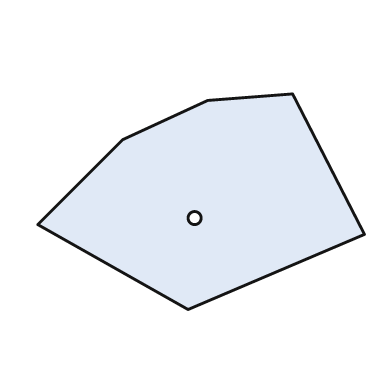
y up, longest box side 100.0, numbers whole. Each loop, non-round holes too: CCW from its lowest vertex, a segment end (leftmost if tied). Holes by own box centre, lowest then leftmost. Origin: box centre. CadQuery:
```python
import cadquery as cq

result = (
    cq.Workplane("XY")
    .moveTo(-4.0, -33.0)
    .lineTo(50.0, -10.0)
    .lineTo(28.0, 33.0)
    .lineTo(2.0, 31.0)
    .lineTo(-24.0, 19.0)
    .lineTo(-50.0, -7.0)
    .close()
    .moveTo(-2.0, -5.0)
    .circle(2.0)
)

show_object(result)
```